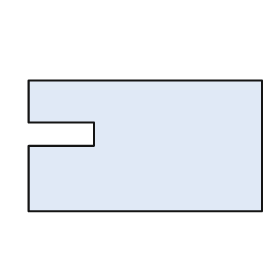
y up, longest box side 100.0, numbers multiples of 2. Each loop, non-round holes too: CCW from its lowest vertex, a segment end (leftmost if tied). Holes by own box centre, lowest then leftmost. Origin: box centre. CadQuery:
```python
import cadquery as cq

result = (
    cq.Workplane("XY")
    .moveTo(-50.0, -28.0)
    .lineTo(50.0, -28.0)
    .lineTo(50.0, 28.0)
    .lineTo(-50.0, 28.0)
    .lineTo(-50.0, 10.0)
    .lineTo(-22.0, 10.0)
    .lineTo(-22.0, 0.0)
    .lineTo(-50.0, 0.0)
    .close()
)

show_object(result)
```